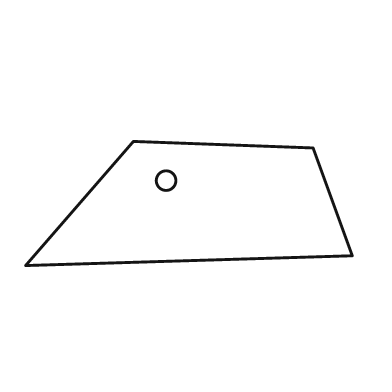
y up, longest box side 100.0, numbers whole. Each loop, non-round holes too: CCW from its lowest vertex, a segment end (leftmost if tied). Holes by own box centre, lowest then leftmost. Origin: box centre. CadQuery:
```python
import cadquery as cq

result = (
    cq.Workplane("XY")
    .moveTo(-50.0, -19.0)
    .lineTo(50.0, -16.0)
    .lineTo(38.0, 17.0)
    .lineTo(-17.0, 19.0)
    .close()
    .moveTo(-7.0, 7.0)
    .circle(3.0)
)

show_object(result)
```